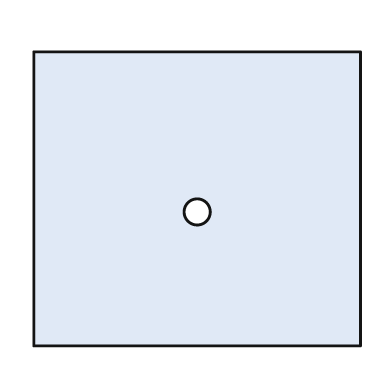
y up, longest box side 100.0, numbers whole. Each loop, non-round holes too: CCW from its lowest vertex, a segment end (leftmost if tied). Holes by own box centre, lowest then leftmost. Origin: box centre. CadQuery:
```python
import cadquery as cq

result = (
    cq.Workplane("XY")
    .moveTo(-50.0, -45.0)
    .lineTo(50.0, -45.0)
    .lineTo(50.0, 45.0)
    .lineTo(-50.0, 45.0)
    .close()
    .moveTo(0.0, -4.0)
    .circle(4.0)
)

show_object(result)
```